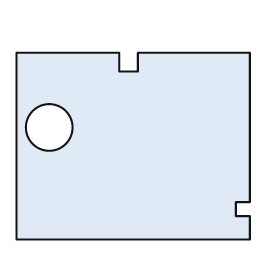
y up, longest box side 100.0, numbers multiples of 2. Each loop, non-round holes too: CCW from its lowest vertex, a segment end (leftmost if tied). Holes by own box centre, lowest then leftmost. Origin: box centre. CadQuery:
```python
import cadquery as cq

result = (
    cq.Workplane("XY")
    .moveTo(-50.0, -40.0)
    .lineTo(50.0, -40.0)
    .lineTo(50.0, -30.0)
    .lineTo(44.0, -30.0)
    .lineTo(44.0, -24.0)
    .lineTo(50.0, -24.0)
    .lineTo(50.0, 40.0)
    .lineTo(2.0, 40.0)
    .lineTo(2.0, 32.0)
    .lineTo(-6.0, 32.0)
    .lineTo(-6.0, 40.0)
    .lineTo(-50.0, 40.0)
    .close()
    .moveTo(-36.0, 8.0)
    .circle(10.0)
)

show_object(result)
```